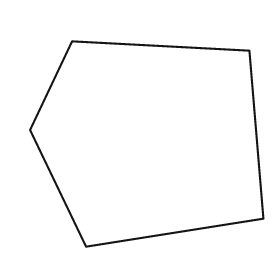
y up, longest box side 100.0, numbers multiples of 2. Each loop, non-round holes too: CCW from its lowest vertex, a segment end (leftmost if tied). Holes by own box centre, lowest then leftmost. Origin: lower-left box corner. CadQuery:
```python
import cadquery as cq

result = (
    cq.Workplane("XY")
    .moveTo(24.0, 0.0)
    .lineTo(100.0, 12.0)
    .lineTo(94.0, 84.0)
    .lineTo(18.0, 88.0)
    .lineTo(0.0, 50.0)
    .close()
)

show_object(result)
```